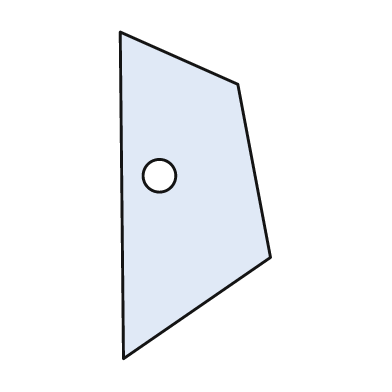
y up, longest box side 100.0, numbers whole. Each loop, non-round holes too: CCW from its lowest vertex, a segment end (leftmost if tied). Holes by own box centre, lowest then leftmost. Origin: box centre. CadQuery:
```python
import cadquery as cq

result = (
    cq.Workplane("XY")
    .moveTo(-22.0, -50.0)
    .lineTo(23.0, -19.0)
    .lineTo(13.0, 34.0)
    .lineTo(-23.0, 50.0)
    .close()
    .moveTo(-11.0, 6.0)
    .circle(5.0)
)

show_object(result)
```